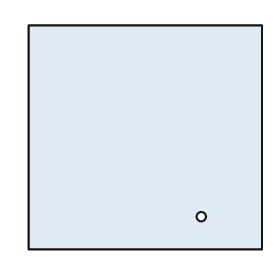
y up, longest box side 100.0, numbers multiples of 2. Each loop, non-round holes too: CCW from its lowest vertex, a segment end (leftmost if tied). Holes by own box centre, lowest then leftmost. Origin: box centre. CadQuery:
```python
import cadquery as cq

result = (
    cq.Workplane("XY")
    .moveTo(-50.0, -48.0)
    .lineTo(50.0, -48.0)
    .lineTo(50.0, 48.0)
    .lineTo(-50.0, 48.0)
    .close()
    .moveTo(24.0, -34.0)
    .circle(2.0)
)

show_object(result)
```